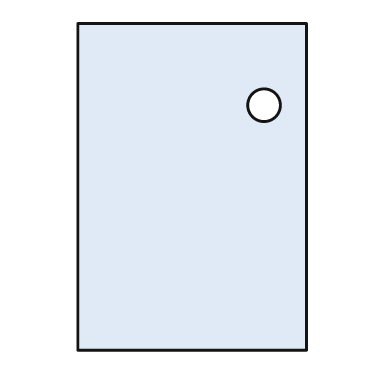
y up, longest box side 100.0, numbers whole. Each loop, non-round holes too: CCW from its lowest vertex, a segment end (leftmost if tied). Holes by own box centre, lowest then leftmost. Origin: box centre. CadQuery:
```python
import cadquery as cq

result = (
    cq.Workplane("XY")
    .moveTo(-35.0, -50.0)
    .lineTo(35.0, -50.0)
    .lineTo(35.0, 50.0)
    .lineTo(-35.0, 50.0)
    .close()
    .moveTo(22.0, 25.0)
    .circle(5.0)
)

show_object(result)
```